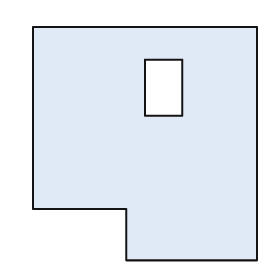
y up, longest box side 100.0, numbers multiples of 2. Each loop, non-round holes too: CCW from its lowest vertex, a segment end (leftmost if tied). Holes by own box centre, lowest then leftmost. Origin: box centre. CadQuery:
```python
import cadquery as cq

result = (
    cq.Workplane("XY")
    .moveTo(-8.0, -50.0)
    .lineTo(48.0, -50.0)
    .lineTo(48.0, 50.0)
    .lineTo(-48.0, 50.0)
    .lineTo(-48.0, -28.0)
    .lineTo(-8.0, -28.0)
    .close()
    .moveTo(0.0, 12.0)
    .lineTo(16.0, 12.0)
    .lineTo(16.0, 36.0)
    .lineTo(0.0, 36.0)
    .close()
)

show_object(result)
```